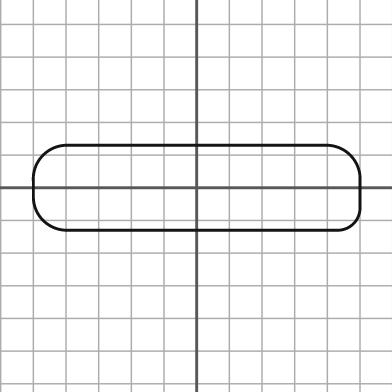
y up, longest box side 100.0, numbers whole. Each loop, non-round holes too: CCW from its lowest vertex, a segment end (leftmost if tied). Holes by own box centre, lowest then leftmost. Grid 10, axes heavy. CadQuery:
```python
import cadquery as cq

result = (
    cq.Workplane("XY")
    .moveTo(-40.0, -13.0)
    .lineTo(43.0, -13.0)
    .threePointArc((48.0, -11.0), (50.0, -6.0))
    .lineTo(50.0, 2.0)
    .threePointArc((47.0, 10.0), (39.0, 13.0))
    .lineTo(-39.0, 13.0)
    .threePointArc((-47.0, 10.0), (-50.0, 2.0))
    .lineTo(-50.0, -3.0)
    .threePointArc((-47.0, -10.0), (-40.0, -13.0))
    .close()
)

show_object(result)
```